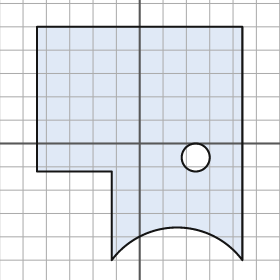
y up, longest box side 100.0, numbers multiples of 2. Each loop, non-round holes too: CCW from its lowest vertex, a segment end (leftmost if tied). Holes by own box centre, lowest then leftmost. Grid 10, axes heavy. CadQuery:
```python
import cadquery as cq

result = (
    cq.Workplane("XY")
    .moveTo(-12.0, -50.0)
    .threePointArc((16.0, -36.0), (44.0, -50.0))
    .lineTo(44.0, 50.0)
    .lineTo(-44.0, 50.0)
    .lineTo(-44.0, -12.0)
    .lineTo(-12.0, -12.0)
    .close()
    .moveTo(24.0, -6.0)
    .circle(6.0)
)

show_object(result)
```